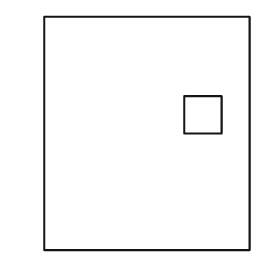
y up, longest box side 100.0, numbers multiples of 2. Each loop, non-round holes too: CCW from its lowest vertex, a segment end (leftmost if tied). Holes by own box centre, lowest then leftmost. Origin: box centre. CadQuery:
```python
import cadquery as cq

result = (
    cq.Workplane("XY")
    .moveTo(-44.0, -50.0)
    .lineTo(44.0, -50.0)
    .lineTo(44.0, 50.0)
    .lineTo(-44.0, 50.0)
    .close()
    .moveTo(16.0, 0.0)
    .lineTo(32.0, 0.0)
    .lineTo(32.0, 16.0)
    .lineTo(16.0, 16.0)
    .close()
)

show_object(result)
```